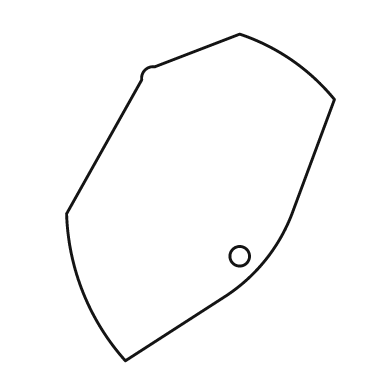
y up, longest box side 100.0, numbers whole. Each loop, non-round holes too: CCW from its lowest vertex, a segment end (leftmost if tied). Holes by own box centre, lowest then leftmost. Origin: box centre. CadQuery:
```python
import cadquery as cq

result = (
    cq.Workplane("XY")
    .moveTo(-23.0, -50.0)
    .lineTo(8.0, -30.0)
    .threePointArc((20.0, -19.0), (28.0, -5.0))
    .lineTo(41.0, 30.0)
    .threePointArc((28.0, 42.0), (12.0, 50.0))
    .lineTo(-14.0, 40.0)
    .threePointArc((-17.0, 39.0), (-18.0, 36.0))
    .lineTo(-41.0, -5.0)
    .threePointArc((-36.0, -29.0), (-23.0, -50.0))
    .close()
    .moveTo(12.0, -18.0)
    .circle(3.0)
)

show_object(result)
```